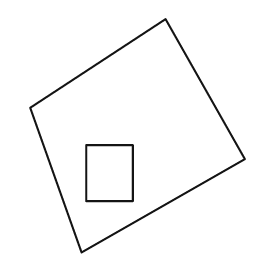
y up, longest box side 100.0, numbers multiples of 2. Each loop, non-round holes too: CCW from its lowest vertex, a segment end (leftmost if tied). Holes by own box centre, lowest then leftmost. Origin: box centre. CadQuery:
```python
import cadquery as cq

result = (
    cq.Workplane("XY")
    .moveTo(-24.0, -50.0)
    .lineTo(46.0, -10.0)
    .lineTo(12.0, 50.0)
    .lineTo(-46.0, 12.0)
    .close()
    .moveTo(-22.0, -28.0)
    .lineTo(-2.0, -28.0)
    .lineTo(-2.0, -4.0)
    .lineTo(-22.0, -4.0)
    .close()
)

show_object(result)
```